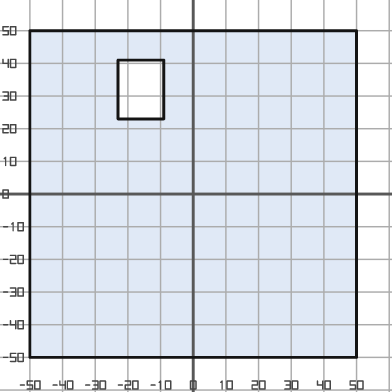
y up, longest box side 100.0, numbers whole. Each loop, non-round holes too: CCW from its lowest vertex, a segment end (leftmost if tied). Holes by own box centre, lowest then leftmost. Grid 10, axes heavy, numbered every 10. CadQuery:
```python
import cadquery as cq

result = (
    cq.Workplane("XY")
    .moveTo(-50.0, -50.0)
    .lineTo(50.0, -50.0)
    .lineTo(50.0, 50.0)
    .lineTo(-50.0, 50.0)
    .close()
    .moveTo(-23.0, 23.0)
    .lineTo(-9.0, 23.0)
    .lineTo(-9.0, 41.0)
    .lineTo(-23.0, 41.0)
    .close()
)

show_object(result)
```